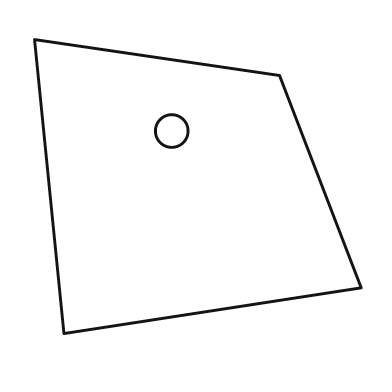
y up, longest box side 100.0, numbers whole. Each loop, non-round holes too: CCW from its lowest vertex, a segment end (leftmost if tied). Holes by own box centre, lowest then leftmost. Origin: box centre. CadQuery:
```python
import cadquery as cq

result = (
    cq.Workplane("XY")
    .moveTo(-41.0, -45.0)
    .lineTo(50.0, -31.0)
    .lineTo(25.0, 34.0)
    .lineTo(-50.0, 45.0)
    .close()
    .moveTo(-8.0, 17.0)
    .circle(5.0)
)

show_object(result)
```